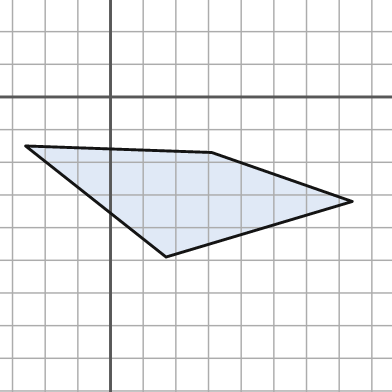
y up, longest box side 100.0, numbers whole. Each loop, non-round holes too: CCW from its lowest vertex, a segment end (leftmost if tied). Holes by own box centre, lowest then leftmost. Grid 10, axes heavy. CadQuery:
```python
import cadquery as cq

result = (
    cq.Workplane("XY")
    .moveTo(17.0, -49.0)
    .lineTo(74.0, -32.0)
    .lineTo(31.0, -17.0)
    .lineTo(-26.0, -15.0)
    .close()
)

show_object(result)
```